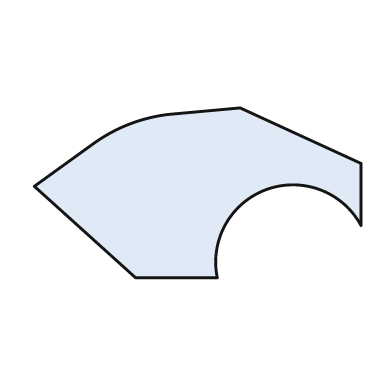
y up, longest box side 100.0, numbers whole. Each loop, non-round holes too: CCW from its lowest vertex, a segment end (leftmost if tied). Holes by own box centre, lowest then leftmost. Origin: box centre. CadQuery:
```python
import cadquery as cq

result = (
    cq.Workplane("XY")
    .moveTo(-19.0, -26.0)
    .lineTo(6.0, -26.0)
    .threePointArc((21.0, 1.0), (50.0, -10.0))
    .lineTo(50.0, 9.0)
    .lineTo(13.0, 26.0)
    .lineTo(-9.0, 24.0)
    .threePointArc((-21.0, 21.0), (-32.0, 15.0))
    .lineTo(-50.0, 2.0)
    .close()
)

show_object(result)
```